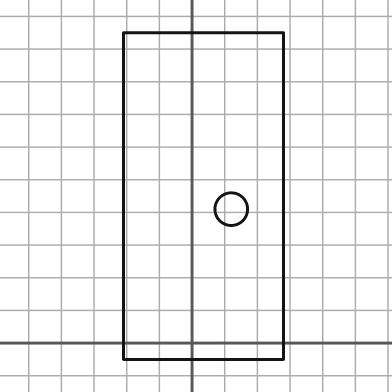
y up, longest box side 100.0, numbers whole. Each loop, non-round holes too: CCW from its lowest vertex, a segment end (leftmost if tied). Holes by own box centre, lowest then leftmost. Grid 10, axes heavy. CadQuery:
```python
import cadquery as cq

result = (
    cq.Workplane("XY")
    .moveTo(-21.0, -5.0)
    .lineTo(28.0, -5.0)
    .lineTo(28.0, 95.0)
    .lineTo(-21.0, 95.0)
    .close()
    .moveTo(12.0, 41.0)
    .circle(5.0)
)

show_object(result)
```